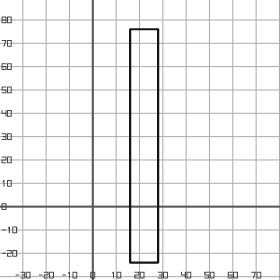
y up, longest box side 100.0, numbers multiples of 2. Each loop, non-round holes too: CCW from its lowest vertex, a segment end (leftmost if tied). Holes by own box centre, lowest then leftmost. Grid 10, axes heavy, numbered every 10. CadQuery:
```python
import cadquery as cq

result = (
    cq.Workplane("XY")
    .moveTo(16.0, -24.0)
    .lineTo(28.0, -24.0)
    .lineTo(28.0, 76.0)
    .lineTo(16.0, 76.0)
    .close()
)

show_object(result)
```